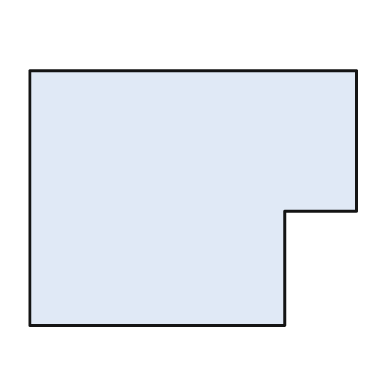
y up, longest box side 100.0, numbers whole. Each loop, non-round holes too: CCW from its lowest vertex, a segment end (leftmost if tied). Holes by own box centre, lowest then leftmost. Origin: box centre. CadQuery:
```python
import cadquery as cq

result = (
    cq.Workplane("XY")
    .moveTo(-50.0, -39.0)
    .lineTo(28.0, -39.0)
    .lineTo(28.0, -4.0)
    .lineTo(50.0, -4.0)
    .lineTo(50.0, 39.0)
    .lineTo(-50.0, 39.0)
    .close()
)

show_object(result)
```